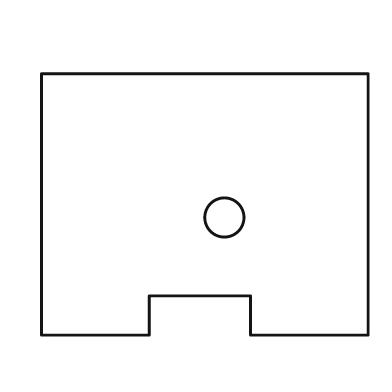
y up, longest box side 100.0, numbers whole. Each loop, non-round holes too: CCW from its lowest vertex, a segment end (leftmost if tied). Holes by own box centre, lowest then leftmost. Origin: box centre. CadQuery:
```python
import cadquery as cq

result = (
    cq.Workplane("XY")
    .moveTo(-50.0, -40.0)
    .lineTo(-17.0, -40.0)
    .lineTo(-17.0, -28.0)
    .lineTo(14.0, -28.0)
    .lineTo(14.0, -40.0)
    .lineTo(50.0, -40.0)
    .lineTo(50.0, 40.0)
    .lineTo(-50.0, 40.0)
    .close()
    .moveTo(6.0, -4.0)
    .circle(6.0)
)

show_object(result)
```